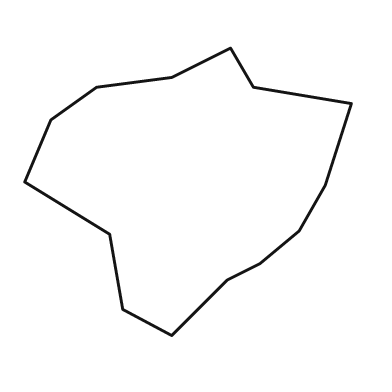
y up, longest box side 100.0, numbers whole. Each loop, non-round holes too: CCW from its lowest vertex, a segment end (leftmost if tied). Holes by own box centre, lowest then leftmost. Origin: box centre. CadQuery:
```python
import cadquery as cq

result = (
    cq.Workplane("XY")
    .moveTo(-5.0, -44.0)
    .lineTo(12.0, -27.0)
    .lineTo(22.0, -22.0)
    .lineTo(34.0, -12.0)
    .lineTo(42.0, 2.0)
    .lineTo(50.0, 27.0)
    .lineTo(20.0, 32.0)
    .lineTo(13.0, 44.0)
    .lineTo(-5.0, 35.0)
    .lineTo(-28.0, 32.0)
    .lineTo(-42.0, 22.0)
    .lineTo(-50.0, 3.0)
    .lineTo(-24.0, -13.0)
    .lineTo(-20.0, -36.0)
    .close()
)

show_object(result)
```